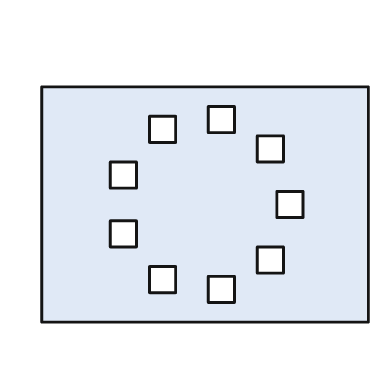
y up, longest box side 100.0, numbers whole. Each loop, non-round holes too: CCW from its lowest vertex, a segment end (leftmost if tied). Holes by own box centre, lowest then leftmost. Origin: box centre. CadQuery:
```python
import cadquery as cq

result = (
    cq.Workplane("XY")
    .moveTo(-50.0, -36.0)
    .lineTo(50.0, -36.0)
    .lineTo(50.0, 36.0)
    .lineTo(-50.0, 36.0)
    .close()
    .moveTo(1.0, -30.0)
    .lineTo(9.0, -30.0)
    .lineTo(9.0, -22.0)
    .lineTo(1.0, -22.0)
    .close()
    .moveTo(-17.0, -27.0)
    .lineTo(-9.0, -27.0)
    .lineTo(-9.0, -19.0)
    .lineTo(-17.0, -19.0)
    .close()
    .moveTo(16.0, -21.0)
    .lineTo(24.0, -21.0)
    .lineTo(24.0, -13.0)
    .lineTo(16.0, -13.0)
    .close()
    .moveTo(-29.0, -13.0)
    .lineTo(-21.0, -13.0)
    .lineTo(-21.0, -5.0)
    .lineTo(-29.0, -5.0)
    .close()
    .moveTo(22.0, -4.0)
    .lineTo(30.0, -4.0)
    .lineTo(30.0, 4.0)
    .lineTo(22.0, 4.0)
    .close()
    .moveTo(-29.0, 5.0)
    .lineTo(-21.0, 5.0)
    .lineTo(-21.0, 13.0)
    .lineTo(-29.0, 13.0)
    .close()
    .moveTo(16.0, 13.0)
    .lineTo(24.0, 13.0)
    .lineTo(24.0, 21.0)
    .lineTo(16.0, 21.0)
    .close()
    .moveTo(-17.0, 19.0)
    .lineTo(-9.0, 19.0)
    .lineTo(-9.0, 27.0)
    .lineTo(-17.0, 27.0)
    .close()
    .moveTo(1.0, 22.0)
    .lineTo(9.0, 22.0)
    .lineTo(9.0, 30.0)
    .lineTo(1.0, 30.0)
    .close()
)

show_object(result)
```